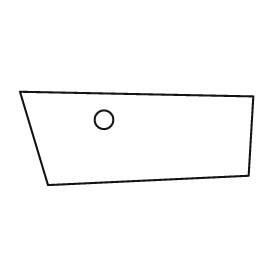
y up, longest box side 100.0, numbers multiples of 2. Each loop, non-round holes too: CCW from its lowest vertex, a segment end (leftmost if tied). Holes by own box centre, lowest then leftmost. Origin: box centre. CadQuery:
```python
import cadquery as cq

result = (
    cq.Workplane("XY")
    .moveTo(-38.0, -20.0)
    .lineTo(48.0, -16.0)
    .lineTo(50.0, 18.0)
    .lineTo(-50.0, 20.0)
    .close()
    .moveTo(-14.0, 8.0)
    .circle(4.0)
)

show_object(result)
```